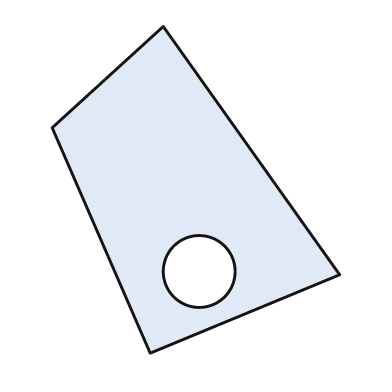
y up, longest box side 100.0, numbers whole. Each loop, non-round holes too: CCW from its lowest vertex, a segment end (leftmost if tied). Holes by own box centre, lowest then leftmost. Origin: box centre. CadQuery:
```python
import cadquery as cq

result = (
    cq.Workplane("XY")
    .moveTo(-14.0, -50.0)
    .lineTo(44.0, -26.0)
    .lineTo(-10.0, 50.0)
    .lineTo(-44.0, 19.0)
    .close()
    .moveTo(1.0, -25.0)
    .circle(11.0)
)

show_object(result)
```